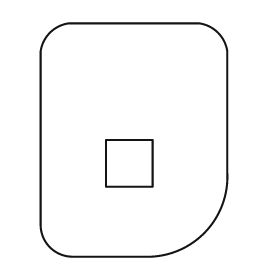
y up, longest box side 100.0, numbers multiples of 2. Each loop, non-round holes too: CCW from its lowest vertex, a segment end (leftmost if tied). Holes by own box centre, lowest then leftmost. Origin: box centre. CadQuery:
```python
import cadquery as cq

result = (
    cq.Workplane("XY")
    .moveTo(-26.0, -50.0)
    .lineTo(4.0, -50.0)
    .threePointArc((30.0, -40.0), (40.0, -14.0))
    .lineTo(40.0, 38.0)
    .threePointArc((36.0, 46.0), (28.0, 50.0))
    .lineTo(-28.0, 50.0)
    .threePointArc((-36.0, 46.0), (-40.0, 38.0))
    .lineTo(-40.0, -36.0)
    .threePointArc((-36.0, -46.0), (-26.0, -50.0))
    .close()
    .moveTo(-12.0, -20.0)
    .lineTo(8.0, -20.0)
    .lineTo(8.0, 0.0)
    .lineTo(-12.0, 0.0)
    .close()
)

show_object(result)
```